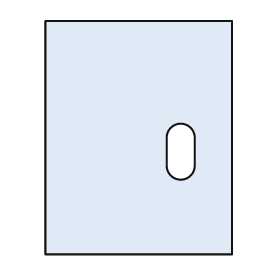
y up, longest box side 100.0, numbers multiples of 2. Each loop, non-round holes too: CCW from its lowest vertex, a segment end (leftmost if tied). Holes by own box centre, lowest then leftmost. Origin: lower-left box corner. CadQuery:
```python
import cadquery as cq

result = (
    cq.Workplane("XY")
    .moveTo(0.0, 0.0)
    .lineTo(80.0, 0.0)
    .lineTo(80.0, 100.0)
    .lineTo(0.0, 100.0)
    .close()
    .moveTo(52.0, 38.0)
    .threePointArc((58.0, 32.0), (64.0, 38.0))
    .lineTo(64.0, 50.0)
    .threePointArc((58.0, 56.0), (52.0, 50.0))
    .close()
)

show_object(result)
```